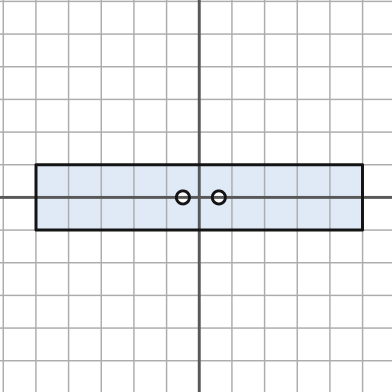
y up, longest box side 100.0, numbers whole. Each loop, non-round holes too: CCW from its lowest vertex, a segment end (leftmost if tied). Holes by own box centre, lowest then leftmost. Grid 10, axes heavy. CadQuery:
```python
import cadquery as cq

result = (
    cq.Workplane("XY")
    .moveTo(-50.0, -10.0)
    .lineTo(50.0, -10.0)
    .lineTo(50.0, 10.0)
    .lineTo(-50.0, 10.0)
    .close()
    .moveTo(-5.0, 0.0)
    .circle(2.0)
    .moveTo(6.0, 0.0)
    .circle(2.0)
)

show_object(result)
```